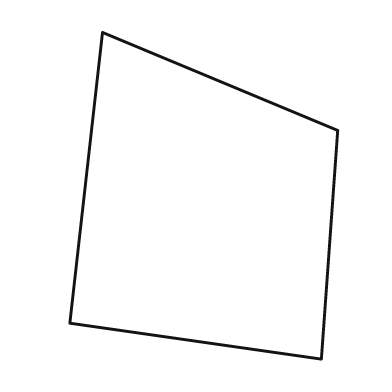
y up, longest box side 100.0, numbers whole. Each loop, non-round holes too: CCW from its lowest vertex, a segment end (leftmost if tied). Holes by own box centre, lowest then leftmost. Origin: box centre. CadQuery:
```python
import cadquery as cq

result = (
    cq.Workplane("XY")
    .moveTo(36.0, -50.0)
    .lineTo(41.0, 20.0)
    .lineTo(-31.0, 50.0)
    .lineTo(-41.0, -39.0)
    .close()
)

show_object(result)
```